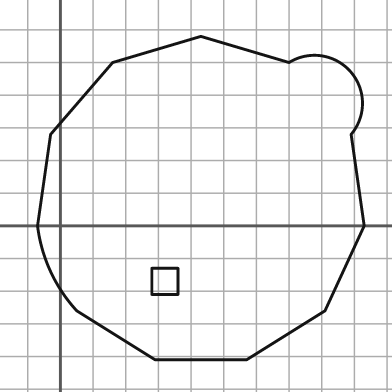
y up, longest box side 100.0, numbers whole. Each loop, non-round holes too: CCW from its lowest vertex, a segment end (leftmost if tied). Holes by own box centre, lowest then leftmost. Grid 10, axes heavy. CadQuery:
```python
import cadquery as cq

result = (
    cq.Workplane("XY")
    .moveTo(29.0, -41.0)
    .lineTo(57.0, -41.0)
    .lineTo(81.0, -26.0)
    .lineTo(93.0, 0.0)
    .lineTo(89.0, 28.0)
    .threePointArc((89.0, 47.0), (70.0, 50.0))
    .lineTo(43.0, 58.0)
    .lineTo(16.0, 50.0)
    .lineTo(-3.0, 28.0)
    .lineTo(-7.0, 0.0)
    .threePointArc((-3.0, -14.0), (5.0, -26.0))
    .close()
    .moveTo(28.0, -21.0)
    .lineTo(36.0, -21.0)
    .lineTo(36.0, -13.0)
    .lineTo(28.0, -13.0)
    .close()
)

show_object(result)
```